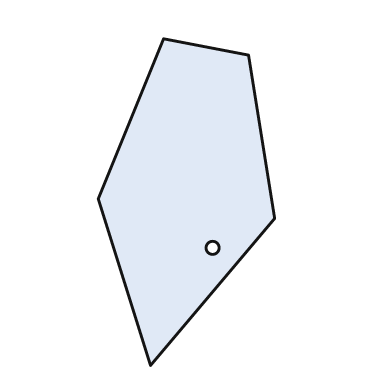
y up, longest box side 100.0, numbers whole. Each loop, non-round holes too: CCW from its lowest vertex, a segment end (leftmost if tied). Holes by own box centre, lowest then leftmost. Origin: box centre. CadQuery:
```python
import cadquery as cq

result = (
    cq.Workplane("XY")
    .moveTo(-11.0, -50.0)
    .lineTo(27.0, -5.0)
    .lineTo(19.0, 45.0)
    .lineTo(-7.0, 50.0)
    .lineTo(-27.0, 1.0)
    .close()
    .moveTo(8.0, -14.0)
    .circle(2.0)
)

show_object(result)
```